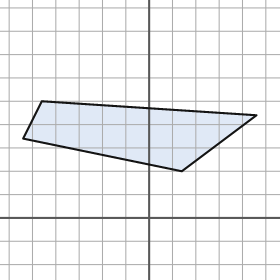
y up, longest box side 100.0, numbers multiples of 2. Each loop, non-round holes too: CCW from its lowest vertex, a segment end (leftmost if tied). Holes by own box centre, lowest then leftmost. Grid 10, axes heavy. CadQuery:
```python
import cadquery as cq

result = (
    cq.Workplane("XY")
    .moveTo(14.0, 20.0)
    .lineTo(46.0, 44.0)
    .lineTo(-46.0, 50.0)
    .lineTo(-54.0, 34.0)
    .close()
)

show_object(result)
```